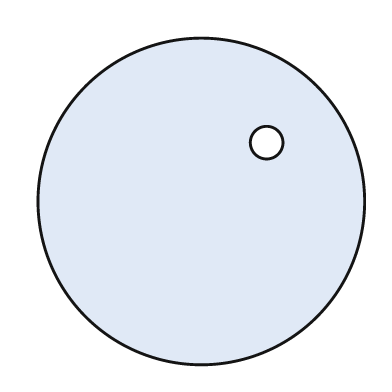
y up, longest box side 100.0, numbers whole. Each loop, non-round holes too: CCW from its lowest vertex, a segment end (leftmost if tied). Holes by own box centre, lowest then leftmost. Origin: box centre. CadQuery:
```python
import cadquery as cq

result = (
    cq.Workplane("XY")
    .moveTo(0.0, 0.0)
    .circle(50.0)
    .moveTo(20.0, 18.0)
    .circle(5.0)
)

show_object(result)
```